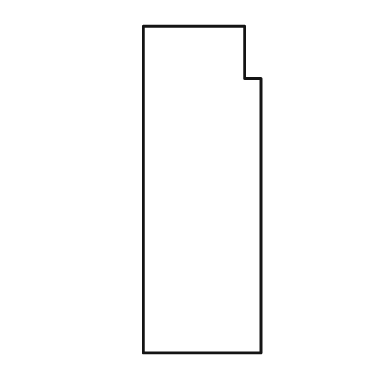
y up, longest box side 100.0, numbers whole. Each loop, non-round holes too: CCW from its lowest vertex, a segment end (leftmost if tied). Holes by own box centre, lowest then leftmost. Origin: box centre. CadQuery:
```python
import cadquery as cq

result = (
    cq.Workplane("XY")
    .moveTo(-18.0, -50.0)
    .lineTo(18.0, -50.0)
    .lineTo(18.0, 34.0)
    .lineTo(13.0, 34.0)
    .lineTo(13.0, 50.0)
    .lineTo(-18.0, 50.0)
    .close()
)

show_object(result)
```